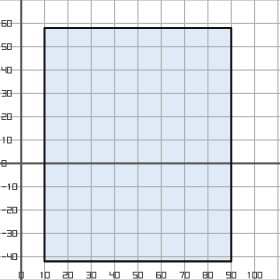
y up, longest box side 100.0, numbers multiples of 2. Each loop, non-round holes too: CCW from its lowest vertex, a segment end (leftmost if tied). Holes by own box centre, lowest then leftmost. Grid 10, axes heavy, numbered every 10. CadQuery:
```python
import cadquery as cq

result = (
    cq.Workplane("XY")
    .moveTo(10.0, -42.0)
    .lineTo(90.0, -42.0)
    .lineTo(90.0, 58.0)
    .lineTo(10.0, 58.0)
    .close()
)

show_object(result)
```